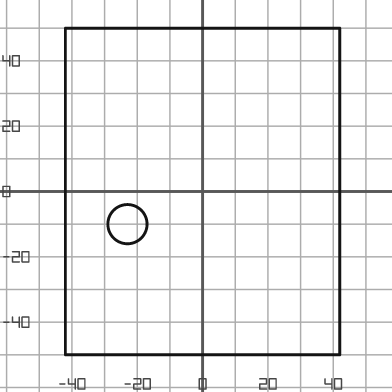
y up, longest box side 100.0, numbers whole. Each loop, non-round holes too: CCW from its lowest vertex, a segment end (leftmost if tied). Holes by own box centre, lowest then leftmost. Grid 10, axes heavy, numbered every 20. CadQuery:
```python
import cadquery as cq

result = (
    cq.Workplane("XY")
    .moveTo(-42.0, -50.0)
    .lineTo(42.0, -50.0)
    .lineTo(42.0, 50.0)
    .lineTo(-42.0, 50.0)
    .close()
    .moveTo(-23.0, -10.0)
    .circle(6.0)
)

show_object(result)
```